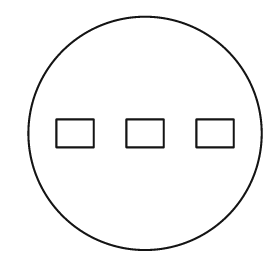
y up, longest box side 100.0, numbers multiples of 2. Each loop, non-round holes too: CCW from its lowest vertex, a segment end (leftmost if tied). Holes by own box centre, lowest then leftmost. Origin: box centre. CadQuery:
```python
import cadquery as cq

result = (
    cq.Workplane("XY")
    .moveTo(0.0, 0.0)
    .circle(50.0)
    .moveTo(-38.0, -6.0)
    .lineTo(-22.0, -6.0)
    .lineTo(-22.0, 6.0)
    .lineTo(-38.0, 6.0)
    .close()
    .moveTo(-8.0, -6.0)
    .lineTo(8.0, -6.0)
    .lineTo(8.0, 6.0)
    .lineTo(-8.0, 6.0)
    .close()
    .moveTo(22.0, -6.0)
    .lineTo(38.0, -6.0)
    .lineTo(38.0, 6.0)
    .lineTo(22.0, 6.0)
    .close()
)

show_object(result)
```